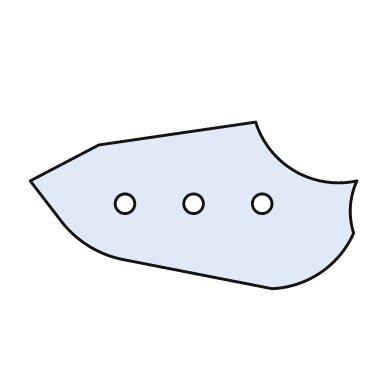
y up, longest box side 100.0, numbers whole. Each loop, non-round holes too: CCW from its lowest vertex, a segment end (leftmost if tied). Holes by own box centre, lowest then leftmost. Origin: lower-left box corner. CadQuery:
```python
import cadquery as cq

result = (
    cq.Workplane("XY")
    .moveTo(74.0, 0.0)
    .threePointArc((89.0, 5.0), (99.0, 17.0))
    .threePointArc((98.0, 25.0), (100.0, 33.0))
    .threePointArc((81.0, 36.0), (69.0, 51.0))
    .lineTo(21.0, 44.0)
    .lineTo(0.0, 33.0)
    .lineTo(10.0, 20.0)
    .threePointArc((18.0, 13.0), (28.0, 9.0))
    .close()
    .moveTo(29.0, 26.0)
    .circle(3.0)
    .moveTo(50.0, 26.0)
    .circle(3.0)
    .moveTo(71.0, 26.0)
    .circle(3.0)
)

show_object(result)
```